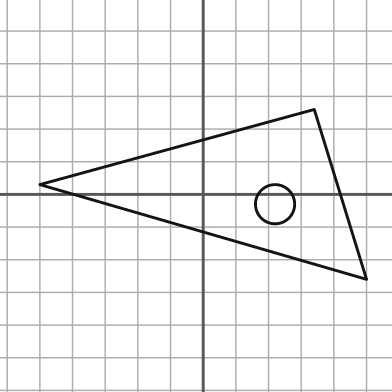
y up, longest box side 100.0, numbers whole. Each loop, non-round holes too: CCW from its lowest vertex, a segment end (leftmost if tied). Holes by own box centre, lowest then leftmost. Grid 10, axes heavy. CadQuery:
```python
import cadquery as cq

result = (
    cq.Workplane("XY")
    .moveTo(50.0, -26.0)
    .lineTo(34.0, 26.0)
    .lineTo(-50.0, 3.0)
    .close()
    .moveTo(22.0, -3.0)
    .circle(6.0)
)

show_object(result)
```